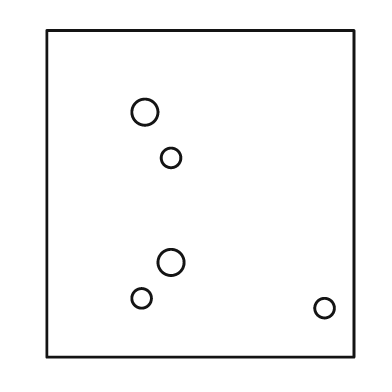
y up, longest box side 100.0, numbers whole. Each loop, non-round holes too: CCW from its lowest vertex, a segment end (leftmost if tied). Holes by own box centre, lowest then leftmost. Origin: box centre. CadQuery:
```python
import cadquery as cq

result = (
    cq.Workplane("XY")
    .moveTo(-47.0, -50.0)
    .lineTo(47.0, -50.0)
    .lineTo(47.0, 50.0)
    .lineTo(-47.0, 50.0)
    .close()
    .moveTo(38.0, -35.0)
    .circle(3.0)
    .moveTo(-18.0, -32.0)
    .circle(3.0)
    .moveTo(-9.0, -21.0)
    .circle(4.0)
    .moveTo(-9.0, 11.0)
    .circle(3.0)
    .moveTo(-17.0, 25.0)
    .circle(4.0)
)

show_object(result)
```